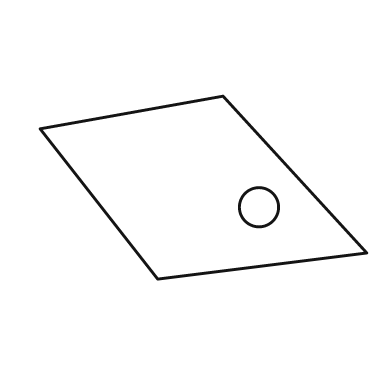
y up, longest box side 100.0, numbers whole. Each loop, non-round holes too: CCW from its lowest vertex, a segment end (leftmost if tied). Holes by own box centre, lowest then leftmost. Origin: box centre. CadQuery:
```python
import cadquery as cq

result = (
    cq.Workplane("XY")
    .moveTo(-14.0, -28.0)
    .lineTo(50.0, -20.0)
    .lineTo(6.0, 28.0)
    .lineTo(-50.0, 18.0)
    .close()
    .moveTo(17.0, -6.0)
    .circle(6.0)
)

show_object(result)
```